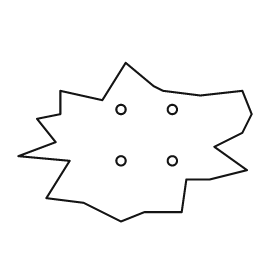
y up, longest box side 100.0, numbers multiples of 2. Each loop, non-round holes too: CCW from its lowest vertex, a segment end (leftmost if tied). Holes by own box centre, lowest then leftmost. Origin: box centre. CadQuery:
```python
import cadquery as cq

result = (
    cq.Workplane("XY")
    .moveTo(-6.0, -34.0)
    .lineTo(4.0, -30.0)
    .lineTo(20.0, -30.0)
    .lineTo(22.0, -16.0)
    .lineTo(32.0, -16.0)
    .lineTo(48.0, -12.0)
    .lineTo(34.0, -2.0)
    .lineTo(46.0, 4.0)
    .lineTo(50.0, 12.0)
    .lineTo(46.0, 22.0)
    .lineTo(28.0, 20.0)
    .lineTo(12.0, 22.0)
    .lineTo(8.0, 24.0)
    .lineTo(-4.0, 34.0)
    .lineTo(-14.0, 18.0)
    .lineTo(-32.0, 22.0)
    .lineTo(-32.0, 12.0)
    .lineTo(-42.0, 10.0)
    .lineTo(-34.0, 0.0)
    .lineTo(-50.0, -6.0)
    .lineTo(-28.0, -8.0)
    .lineTo(-38.0, -24.0)
    .lineTo(-22.0, -26.0)
    .close()
    .moveTo(-6.0, -8.0)
    .circle(2.0)
    .moveTo(16.0, -8.0)
    .circle(2.0)
    .moveTo(-6.0, 14.0)
    .circle(2.0)
    .moveTo(16.0, 14.0)
    .circle(2.0)
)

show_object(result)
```